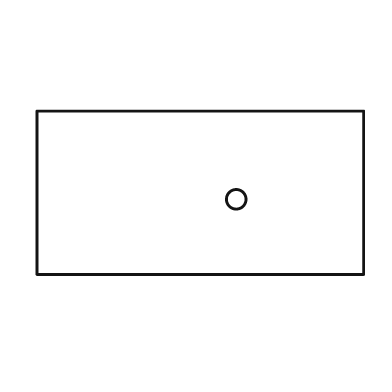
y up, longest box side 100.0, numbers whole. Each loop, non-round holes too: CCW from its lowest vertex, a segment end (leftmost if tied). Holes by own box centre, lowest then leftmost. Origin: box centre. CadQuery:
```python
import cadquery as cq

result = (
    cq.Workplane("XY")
    .moveTo(-50.0, -25.0)
    .lineTo(50.0, -25.0)
    .lineTo(50.0, 25.0)
    .lineTo(-50.0, 25.0)
    .close()
    .moveTo(11.0, -2.0)
    .circle(3.0)
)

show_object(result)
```